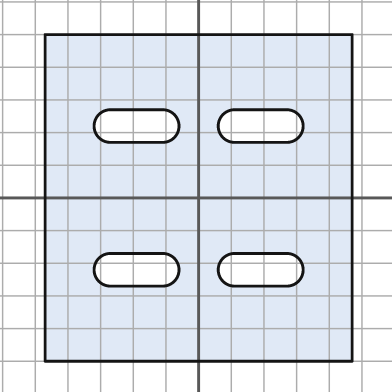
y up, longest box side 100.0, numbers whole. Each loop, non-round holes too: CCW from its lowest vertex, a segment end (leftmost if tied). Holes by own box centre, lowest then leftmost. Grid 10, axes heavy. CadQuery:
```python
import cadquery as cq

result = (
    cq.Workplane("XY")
    .moveTo(-47.0, -50.0)
    .lineTo(47.0, -50.0)
    .lineTo(47.0, 50.0)
    .lineTo(-47.0, 50.0)
    .close()
    .moveTo(-27.0, -27.0)
    .lineTo(-11.0, -27.0)
    .threePointArc((-6.0, -22.0), (-11.0, -17.0))
    .lineTo(-27.0, -17.0)
    .threePointArc((-32.0, -22.0), (-27.0, -27.0))
    .close()
    .moveTo(11.0, -27.0)
    .lineTo(27.0, -27.0)
    .threePointArc((32.0, -22.0), (27.0, -17.0))
    .lineTo(11.0, -17.0)
    .threePointArc((6.0, -22.0), (11.0, -27.0))
    .close()
    .moveTo(-27.0, 17.0)
    .lineTo(-11.0, 17.0)
    .threePointArc((-6.0, 22.0), (-11.0, 27.0))
    .lineTo(-27.0, 27.0)
    .threePointArc((-32.0, 22.0), (-27.0, 17.0))
    .close()
    .moveTo(11.0, 17.0)
    .lineTo(27.0, 17.0)
    .threePointArc((32.0, 22.0), (27.0, 27.0))
    .lineTo(11.0, 27.0)
    .threePointArc((6.0, 22.0), (11.0, 17.0))
    .close()
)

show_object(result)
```